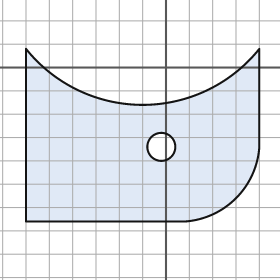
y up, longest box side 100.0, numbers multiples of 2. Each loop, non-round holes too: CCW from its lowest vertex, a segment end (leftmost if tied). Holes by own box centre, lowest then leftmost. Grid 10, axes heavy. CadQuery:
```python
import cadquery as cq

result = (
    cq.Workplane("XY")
    .moveTo(-60.0, -66.0)
    .lineTo(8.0, -66.0)
    .threePointArc((30.0, -56.0), (40.0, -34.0))
    .lineTo(40.0, 8.0)
    .threePointArc((-10.0, -16.0), (-60.0, 8.0))
    .close()
    .moveTo(-2.0, -34.0)
    .circle(6.0)
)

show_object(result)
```